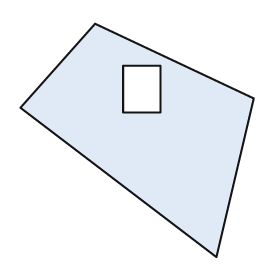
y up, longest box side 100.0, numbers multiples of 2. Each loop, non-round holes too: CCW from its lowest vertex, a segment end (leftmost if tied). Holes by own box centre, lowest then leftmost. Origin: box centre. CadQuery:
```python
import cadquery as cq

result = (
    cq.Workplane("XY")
    .moveTo(34.0, -50.0)
    .lineTo(50.0, 18.0)
    .lineTo(-18.0, 50.0)
    .lineTo(-50.0, 14.0)
    .close()
    .moveTo(-6.0, 12.0)
    .lineTo(10.0, 12.0)
    .lineTo(10.0, 32.0)
    .lineTo(-6.0, 32.0)
    .close()
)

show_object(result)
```